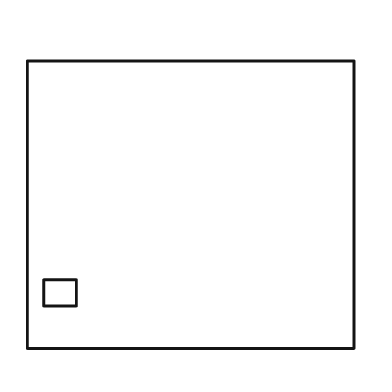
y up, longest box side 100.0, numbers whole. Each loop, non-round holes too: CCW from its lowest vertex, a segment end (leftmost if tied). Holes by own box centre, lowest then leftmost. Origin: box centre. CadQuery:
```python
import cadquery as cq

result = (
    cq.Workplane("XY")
    .moveTo(-50.0, -44.0)
    .lineTo(50.0, -44.0)
    .lineTo(50.0, 44.0)
    .lineTo(-50.0, 44.0)
    .close()
    .moveTo(-45.0, -31.0)
    .lineTo(-35.0, -31.0)
    .lineTo(-35.0, -23.0)
    .lineTo(-45.0, -23.0)
    .close()
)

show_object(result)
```